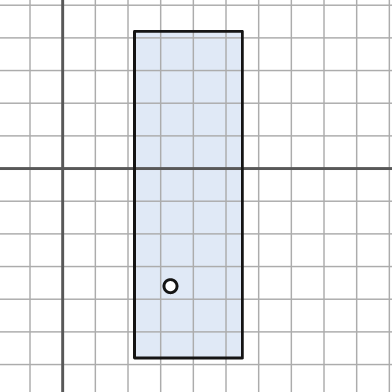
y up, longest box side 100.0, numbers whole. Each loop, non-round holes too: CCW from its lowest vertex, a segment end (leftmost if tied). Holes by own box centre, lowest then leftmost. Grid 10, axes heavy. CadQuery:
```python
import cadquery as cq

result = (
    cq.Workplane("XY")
    .moveTo(22.0, -58.0)
    .lineTo(55.0, -58.0)
    .lineTo(55.0, 42.0)
    .lineTo(22.0, 42.0)
    .close()
    .moveTo(33.0, -36.0)
    .circle(2.0)
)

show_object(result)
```